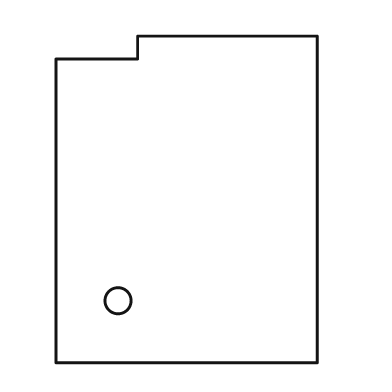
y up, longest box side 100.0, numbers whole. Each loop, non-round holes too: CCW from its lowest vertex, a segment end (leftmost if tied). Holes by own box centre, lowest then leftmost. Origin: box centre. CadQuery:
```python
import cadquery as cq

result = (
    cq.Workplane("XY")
    .moveTo(-40.0, -50.0)
    .lineTo(40.0, -50.0)
    .lineTo(40.0, 50.0)
    .lineTo(-15.0, 50.0)
    .lineTo(-15.0, 43.0)
    .lineTo(-40.0, 43.0)
    .close()
    .moveTo(-21.0, -31.0)
    .circle(4.0)
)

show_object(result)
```